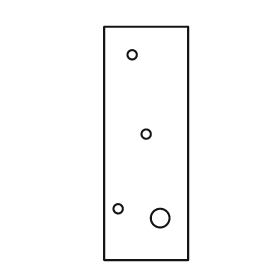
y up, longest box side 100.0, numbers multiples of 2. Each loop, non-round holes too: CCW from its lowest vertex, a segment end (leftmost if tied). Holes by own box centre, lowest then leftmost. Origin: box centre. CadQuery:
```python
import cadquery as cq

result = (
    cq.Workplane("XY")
    .moveTo(-18.0, -50.0)
    .lineTo(18.0, -50.0)
    .lineTo(18.0, 50.0)
    .lineTo(-18.0, 50.0)
    .close()
    .moveTo(6.0, -32.0)
    .circle(4.0)
    .moveTo(-12.0, -28.0)
    .circle(2.0)
    .moveTo(0.0, 4.0)
    .circle(2.0)
    .moveTo(-6.0, 38.0)
    .circle(2.0)
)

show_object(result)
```